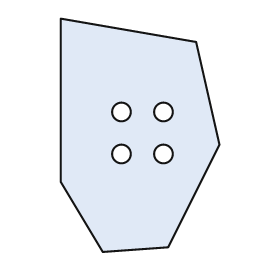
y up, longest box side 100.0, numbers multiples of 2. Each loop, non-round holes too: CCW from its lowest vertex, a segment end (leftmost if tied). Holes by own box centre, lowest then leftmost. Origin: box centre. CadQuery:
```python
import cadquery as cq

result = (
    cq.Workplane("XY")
    .moveTo(-16.0, -50.0)
    .lineTo(12.0, -48.0)
    .lineTo(34.0, -4.0)
    .lineTo(24.0, 40.0)
    .lineTo(-34.0, 50.0)
    .lineTo(-34.0, -20.0)
    .close()
    .moveTo(-8.0, -8.0)
    .circle(4.0)
    .moveTo(10.0, -8.0)
    .circle(4.0)
    .moveTo(-8.0, 10.0)
    .circle(4.0)
    .moveTo(10.0, 10.0)
    .circle(4.0)
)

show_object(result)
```